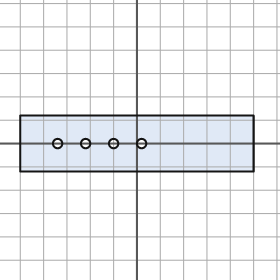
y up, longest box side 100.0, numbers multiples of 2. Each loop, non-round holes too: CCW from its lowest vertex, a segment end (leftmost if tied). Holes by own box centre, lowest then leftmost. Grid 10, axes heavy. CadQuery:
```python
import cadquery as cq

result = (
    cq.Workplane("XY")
    .moveTo(-50.0, -12.0)
    .lineTo(50.0, -12.0)
    .lineTo(50.0, 12.0)
    .lineTo(-50.0, 12.0)
    .close()
    .moveTo(-34.0, 0.0)
    .circle(2.0)
    .moveTo(-22.0, 0.0)
    .circle(2.0)
    .moveTo(-10.0, 0.0)
    .circle(2.0)
    .moveTo(2.0, 0.0)
    .circle(2.0)
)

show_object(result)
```